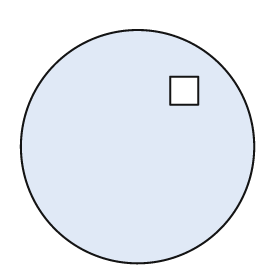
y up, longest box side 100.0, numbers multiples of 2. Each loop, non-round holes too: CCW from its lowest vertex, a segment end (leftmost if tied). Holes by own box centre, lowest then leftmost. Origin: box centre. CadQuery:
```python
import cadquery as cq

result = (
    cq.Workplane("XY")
    .moveTo(0.0, 0.0)
    .circle(50.0)
    .moveTo(14.0, 18.0)
    .lineTo(26.0, 18.0)
    .lineTo(26.0, 30.0)
    .lineTo(14.0, 30.0)
    .close()
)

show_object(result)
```